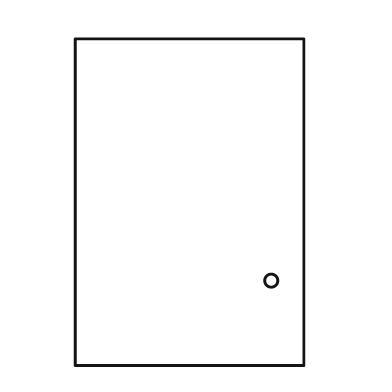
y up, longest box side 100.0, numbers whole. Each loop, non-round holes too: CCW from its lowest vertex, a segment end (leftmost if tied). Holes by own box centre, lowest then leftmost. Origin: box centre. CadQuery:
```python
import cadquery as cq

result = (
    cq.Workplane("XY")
    .moveTo(-35.0, -50.0)
    .lineTo(35.0, -50.0)
    .lineTo(35.0, 50.0)
    .lineTo(-35.0, 50.0)
    .close()
    .moveTo(25.0, -24.0)
    .circle(2.0)
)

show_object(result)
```